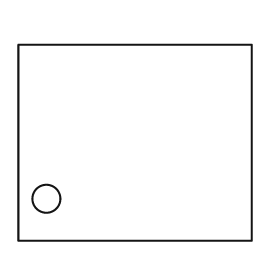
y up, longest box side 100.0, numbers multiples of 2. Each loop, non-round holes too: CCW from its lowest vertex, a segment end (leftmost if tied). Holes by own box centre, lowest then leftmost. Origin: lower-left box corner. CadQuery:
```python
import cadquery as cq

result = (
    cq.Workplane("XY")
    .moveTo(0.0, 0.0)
    .lineTo(100.0, 0.0)
    .lineTo(100.0, 84.0)
    .lineTo(0.0, 84.0)
    .close()
    .moveTo(12.0, 18.0)
    .circle(6.0)
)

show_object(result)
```